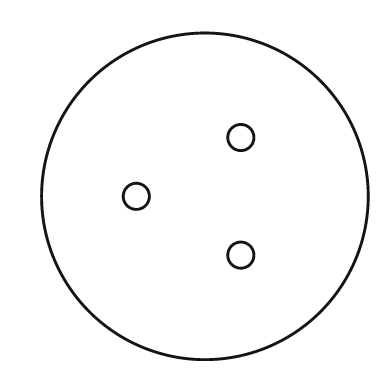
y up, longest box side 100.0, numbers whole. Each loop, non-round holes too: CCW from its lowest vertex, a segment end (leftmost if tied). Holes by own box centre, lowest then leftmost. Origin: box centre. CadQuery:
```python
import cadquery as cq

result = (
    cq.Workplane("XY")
    .moveTo(0.0, 0.0)
    .circle(50.0)
    .moveTo(11.0, -18.0)
    .circle(4.0)
    .moveTo(-21.0, 0.0)
    .circle(4.0)
    .moveTo(11.0, 18.0)
    .circle(4.0)
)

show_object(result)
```